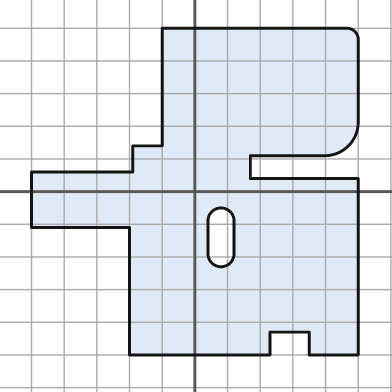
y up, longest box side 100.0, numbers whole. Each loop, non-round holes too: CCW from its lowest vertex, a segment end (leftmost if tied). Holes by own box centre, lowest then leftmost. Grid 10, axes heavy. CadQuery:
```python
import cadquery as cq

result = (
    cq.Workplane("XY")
    .moveTo(-20.0, -50.0)
    .lineTo(23.0, -50.0)
    .lineTo(23.0, -43.0)
    .lineTo(35.0, -43.0)
    .lineTo(35.0, -50.0)
    .lineTo(50.0, -50.0)
    .lineTo(50.0, 4.0)
    .lineTo(17.0, 4.0)
    .lineTo(17.0, 11.0)
    .lineTo(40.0, 11.0)
    .threePointArc((47.0, 14.0), (50.0, 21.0))
    .lineTo(50.0, 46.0)
    .threePointArc((49.0, 49.0), (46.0, 50.0))
    .lineTo(-10.0, 50.0)
    .lineTo(-10.0, 14.0)
    .lineTo(-19.0, 14.0)
    .lineTo(-19.0, 6.0)
    .lineTo(-50.0, 6.0)
    .lineTo(-50.0, -11.0)
    .lineTo(-20.0, -11.0)
    .close()
    .moveTo(4.0, -19.0)
    .threePointArc((8.0, -23.0), (12.0, -19.0))
    .lineTo(12.0, -9.0)
    .threePointArc((8.0, -5.0), (4.0, -9.0))
    .close()
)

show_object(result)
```